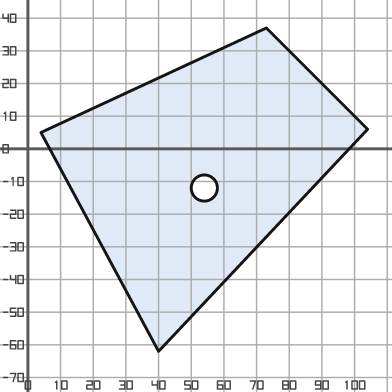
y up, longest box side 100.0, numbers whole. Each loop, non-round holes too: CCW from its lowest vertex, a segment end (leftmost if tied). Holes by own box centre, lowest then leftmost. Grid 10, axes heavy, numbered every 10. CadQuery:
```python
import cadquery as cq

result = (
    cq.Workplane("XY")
    .moveTo(40.0, -62.0)
    .lineTo(104.0, 6.0)
    .lineTo(73.0, 37.0)
    .lineTo(4.0, 5.0)
    .close()
    .moveTo(54.0, -12.0)
    .circle(4.0)
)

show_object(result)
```